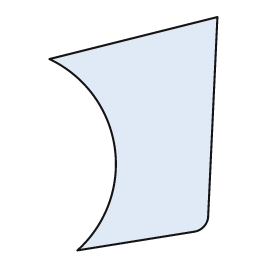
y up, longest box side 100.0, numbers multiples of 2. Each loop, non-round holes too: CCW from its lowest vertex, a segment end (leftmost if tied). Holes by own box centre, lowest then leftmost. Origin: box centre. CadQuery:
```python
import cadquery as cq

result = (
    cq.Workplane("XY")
    .moveTo(-24.0, -50.0)
    .lineTo(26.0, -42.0)
    .threePointArc((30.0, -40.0), (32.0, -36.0))
    .lineTo(36.0, 50.0)
    .lineTo(-36.0, 32.0)
    .threePointArc((-8.0, -6.0), (-24.0, -50.0))
    .close()
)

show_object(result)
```